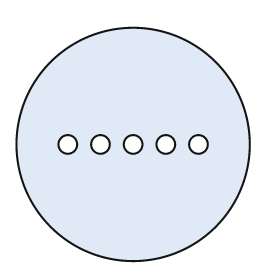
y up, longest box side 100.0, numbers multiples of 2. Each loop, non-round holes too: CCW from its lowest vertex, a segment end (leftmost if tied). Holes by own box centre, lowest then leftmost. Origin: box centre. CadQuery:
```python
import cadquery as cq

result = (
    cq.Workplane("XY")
    .moveTo(0.0, 0.0)
    .circle(50.0)
    .moveTo(-28.0, 0.0)
    .circle(4.0)
    .moveTo(-14.0, 0.0)
    .circle(4.0)
    .moveTo(0.0, 0.0)
    .circle(4.0)
    .moveTo(14.0, 0.0)
    .circle(4.0)
    .moveTo(28.0, 0.0)
    .circle(4.0)
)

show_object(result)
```